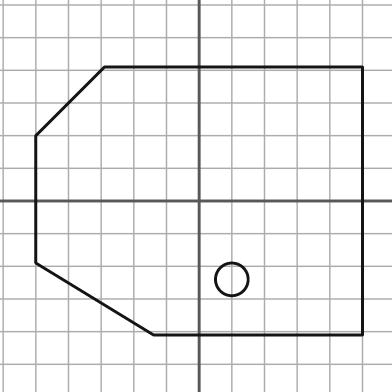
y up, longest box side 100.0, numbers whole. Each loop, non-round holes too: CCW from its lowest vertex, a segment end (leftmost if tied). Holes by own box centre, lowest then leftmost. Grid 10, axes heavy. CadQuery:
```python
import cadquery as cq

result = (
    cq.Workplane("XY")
    .moveTo(-14.0, -41.0)
    .lineTo(50.0, -41.0)
    .lineTo(50.0, 41.0)
    .lineTo(-29.0, 41.0)
    .lineTo(-50.0, 20.0)
    .lineTo(-50.0, -19.0)
    .close()
    .moveTo(10.0, -24.0)
    .circle(5.0)
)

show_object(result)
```